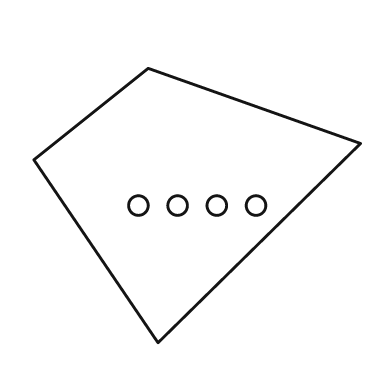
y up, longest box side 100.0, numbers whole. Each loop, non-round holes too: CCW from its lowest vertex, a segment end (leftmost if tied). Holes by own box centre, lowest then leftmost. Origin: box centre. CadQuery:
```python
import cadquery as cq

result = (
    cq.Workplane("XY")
    .moveTo(-12.0, -42.0)
    .lineTo(50.0, 19.0)
    .lineTo(-15.0, 42.0)
    .lineTo(-50.0, 14.0)
    .close()
    .moveTo(-18.0, 0.0)
    .circle(3.0)
    .moveTo(-6.0, 0.0)
    .circle(3.0)
    .moveTo(6.0, 0.0)
    .circle(3.0)
    .moveTo(18.0, 0.0)
    .circle(3.0)
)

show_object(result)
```